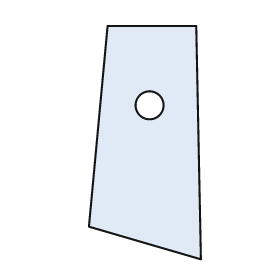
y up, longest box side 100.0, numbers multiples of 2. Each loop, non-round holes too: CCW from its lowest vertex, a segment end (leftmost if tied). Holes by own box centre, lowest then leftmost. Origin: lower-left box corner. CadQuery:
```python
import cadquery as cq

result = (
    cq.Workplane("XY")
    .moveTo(48.0, 0.0)
    .lineTo(46.0, 100.0)
    .lineTo(8.0, 100.0)
    .lineTo(0.0, 14.0)
    .close()
    .moveTo(26.0, 66.0)
    .circle(6.0)
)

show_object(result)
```